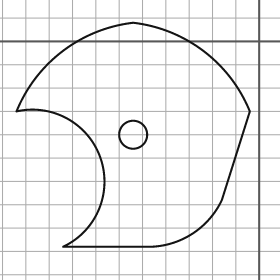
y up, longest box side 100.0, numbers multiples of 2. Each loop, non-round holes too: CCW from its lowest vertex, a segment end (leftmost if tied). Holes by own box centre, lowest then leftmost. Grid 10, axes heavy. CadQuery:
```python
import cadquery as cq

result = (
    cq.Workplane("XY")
    .moveTo(-84.0, -88.0)
    .lineTo(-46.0, -88.0)
    .threePointArc((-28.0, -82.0), (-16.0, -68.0))
    .lineTo(-4.0, -30.0)
    .threePointArc((-24.0, -4.0), (-54.0, 8.0))
    .threePointArc((-84.0, -4.0), (-104.0, -30.0))
    .threePointArc((-68.0, -50.0), (-84.0, -88.0))
    .close()
    .moveTo(-54.0, -40.0)
    .circle(6.0)
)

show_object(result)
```